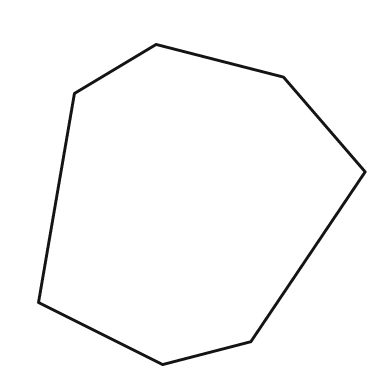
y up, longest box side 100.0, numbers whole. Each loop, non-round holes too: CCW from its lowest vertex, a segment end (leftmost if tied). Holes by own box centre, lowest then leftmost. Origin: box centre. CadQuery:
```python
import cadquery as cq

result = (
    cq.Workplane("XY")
    .moveTo(-12.0, -49.0)
    .lineTo(15.0, -42.0)
    .lineTo(50.0, 10.0)
    .lineTo(25.0, 39.0)
    .lineTo(-14.0, 49.0)
    .lineTo(-39.0, 34.0)
    .lineTo(-50.0, -30.0)
    .close()
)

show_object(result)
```